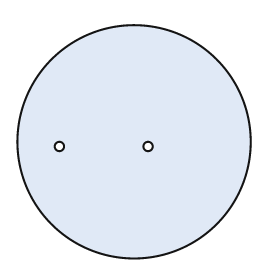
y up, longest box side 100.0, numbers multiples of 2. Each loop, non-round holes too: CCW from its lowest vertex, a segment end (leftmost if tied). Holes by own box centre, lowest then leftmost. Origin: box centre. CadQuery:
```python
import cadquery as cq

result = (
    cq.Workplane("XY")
    .moveTo(0.0, 0.0)
    .circle(50.0)
    .moveTo(-32.0, -2.0)
    .circle(2.0)
    .moveTo(6.0, -2.0)
    .circle(2.0)
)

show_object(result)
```